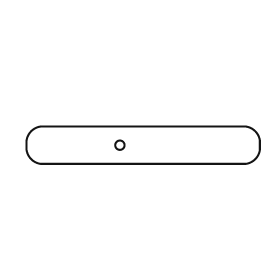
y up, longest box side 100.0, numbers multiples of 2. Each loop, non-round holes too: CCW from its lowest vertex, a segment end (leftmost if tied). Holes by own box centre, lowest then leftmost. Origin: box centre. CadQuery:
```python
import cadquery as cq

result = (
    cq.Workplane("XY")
    .moveTo(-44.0, -8.0)
    .lineTo(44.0, -8.0)
    .threePointArc((48.0, -6.0), (50.0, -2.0))
    .lineTo(50.0, 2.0)
    .threePointArc((48.0, 6.0), (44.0, 8.0))
    .lineTo(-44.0, 8.0)
    .threePointArc((-48.0, 6.0), (-50.0, 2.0))
    .lineTo(-50.0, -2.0)
    .threePointArc((-48.0, -6.0), (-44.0, -8.0))
    .close()
    .moveTo(-10.0, 0.0)
    .circle(2.0)
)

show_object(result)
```